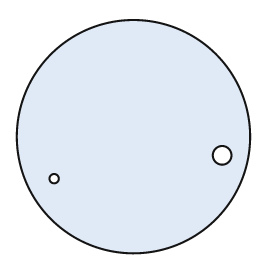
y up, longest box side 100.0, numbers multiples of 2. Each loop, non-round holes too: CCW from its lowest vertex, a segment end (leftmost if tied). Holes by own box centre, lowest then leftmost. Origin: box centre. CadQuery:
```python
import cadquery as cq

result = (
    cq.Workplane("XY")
    .moveTo(0.0, 0.0)
    .circle(50.0)
    .moveTo(-34.0, -18.0)
    .circle(2.0)
    .moveTo(38.0, -8.0)
    .circle(4.0)
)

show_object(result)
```